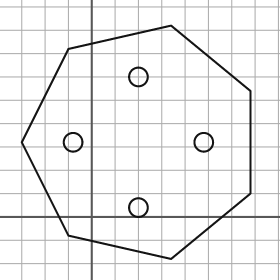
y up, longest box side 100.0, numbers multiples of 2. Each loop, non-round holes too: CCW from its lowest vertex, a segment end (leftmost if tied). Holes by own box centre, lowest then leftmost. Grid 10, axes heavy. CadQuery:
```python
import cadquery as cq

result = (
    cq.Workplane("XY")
    .moveTo(34.0, -18.0)
    .lineTo(68.0, 10.0)
    .lineTo(68.0, 54.0)
    .lineTo(34.0, 82.0)
    .lineTo(-10.0, 72.0)
    .lineTo(-30.0, 32.0)
    .lineTo(-10.0, -8.0)
    .close()
    .moveTo(20.0, 4.0)
    .circle(4.0)
    .moveTo(-8.0, 32.0)
    .circle(4.0)
    .moveTo(48.0, 32.0)
    .circle(4.0)
    .moveTo(20.0, 60.0)
    .circle(4.0)
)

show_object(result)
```